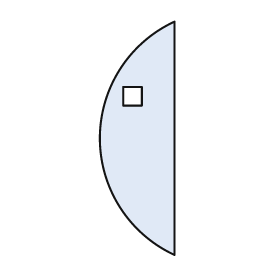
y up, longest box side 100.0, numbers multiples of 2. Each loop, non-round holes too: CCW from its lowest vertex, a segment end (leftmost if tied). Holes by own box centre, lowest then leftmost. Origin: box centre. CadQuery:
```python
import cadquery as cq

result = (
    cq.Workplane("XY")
    .moveTo(16.0, -50.0)
    .lineTo(16.0, 50.0)
    .threePointArc((-16.0, 0.0), (16.0, -50.0))
    .close()
    .moveTo(-6.0, 14.0)
    .lineTo(2.0, 14.0)
    .lineTo(2.0, 22.0)
    .lineTo(-6.0, 22.0)
    .close()
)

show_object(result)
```